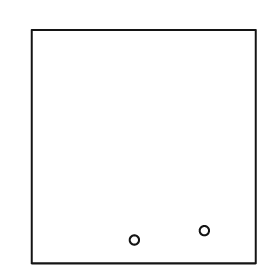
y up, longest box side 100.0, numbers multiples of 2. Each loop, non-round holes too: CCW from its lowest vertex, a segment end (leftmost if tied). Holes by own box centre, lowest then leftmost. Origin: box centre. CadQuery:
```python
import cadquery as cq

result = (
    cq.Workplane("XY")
    .moveTo(-48.0, -50.0)
    .lineTo(48.0, -50.0)
    .lineTo(48.0, 50.0)
    .lineTo(-48.0, 50.0)
    .close()
    .moveTo(-4.0, -40.0)
    .circle(2.0)
    .moveTo(26.0, -36.0)
    .circle(2.0)
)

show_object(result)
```